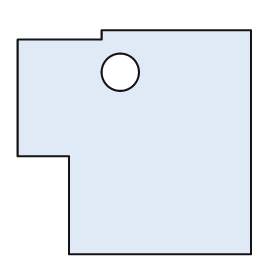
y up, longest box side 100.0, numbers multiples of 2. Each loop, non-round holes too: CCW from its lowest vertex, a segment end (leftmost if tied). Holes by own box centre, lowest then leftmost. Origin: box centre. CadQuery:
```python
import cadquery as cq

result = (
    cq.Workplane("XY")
    .moveTo(-28.0, -48.0)
    .lineTo(50.0, -48.0)
    .lineTo(50.0, 48.0)
    .lineTo(-14.0, 48.0)
    .lineTo(-14.0, 44.0)
    .lineTo(-50.0, 44.0)
    .lineTo(-50.0, -6.0)
    .lineTo(-28.0, -6.0)
    .close()
    .moveTo(-6.0, 30.0)
    .circle(8.0)
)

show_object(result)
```